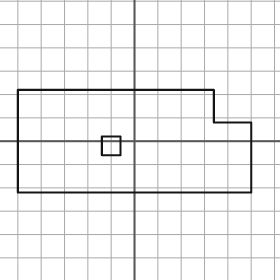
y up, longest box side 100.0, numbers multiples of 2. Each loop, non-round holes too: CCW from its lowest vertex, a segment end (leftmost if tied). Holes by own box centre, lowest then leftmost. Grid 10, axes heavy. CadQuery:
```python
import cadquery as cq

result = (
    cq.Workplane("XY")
    .moveTo(-50.0, -22.0)
    .lineTo(50.0, -22.0)
    .lineTo(50.0, 8.0)
    .lineTo(34.0, 8.0)
    .lineTo(34.0, 22.0)
    .lineTo(-50.0, 22.0)
    .close()
    .moveTo(-14.0, -6.0)
    .lineTo(-6.0, -6.0)
    .lineTo(-6.0, 2.0)
    .lineTo(-14.0, 2.0)
    .close()
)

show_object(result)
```